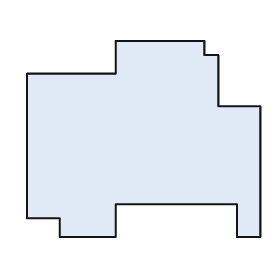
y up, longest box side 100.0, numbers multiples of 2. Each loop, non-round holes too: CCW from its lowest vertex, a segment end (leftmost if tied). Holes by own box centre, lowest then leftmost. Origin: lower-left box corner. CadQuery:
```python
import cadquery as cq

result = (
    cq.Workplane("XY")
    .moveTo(14.0, 0.0)
    .lineTo(38.0, 0.0)
    .lineTo(38.0, 14.0)
    .lineTo(90.0, 14.0)
    .lineTo(90.0, 0.0)
    .lineTo(100.0, 0.0)
    .lineTo(100.0, 56.0)
    .lineTo(82.0, 56.0)
    .lineTo(82.0, 78.0)
    .lineTo(76.0, 78.0)
    .lineTo(76.0, 84.0)
    .lineTo(38.0, 84.0)
    .lineTo(38.0, 70.0)
    .lineTo(0.0, 70.0)
    .lineTo(0.0, 8.0)
    .lineTo(14.0, 8.0)
    .close()
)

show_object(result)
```